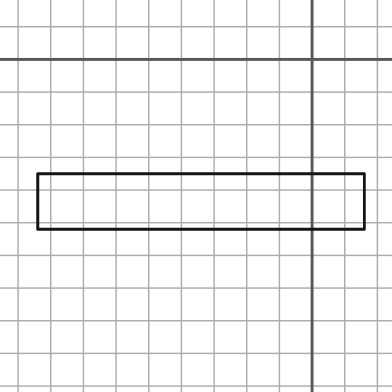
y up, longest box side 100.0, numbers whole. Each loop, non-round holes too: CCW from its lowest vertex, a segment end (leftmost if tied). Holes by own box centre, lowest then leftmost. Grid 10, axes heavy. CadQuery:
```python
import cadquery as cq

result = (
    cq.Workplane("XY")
    .moveTo(-84.0, -52.0)
    .lineTo(16.0, -52.0)
    .lineTo(16.0, -35.0)
    .lineTo(-84.0, -35.0)
    .close()
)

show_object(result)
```